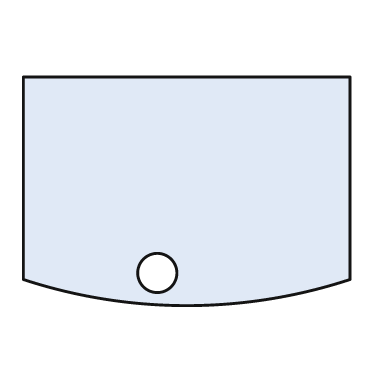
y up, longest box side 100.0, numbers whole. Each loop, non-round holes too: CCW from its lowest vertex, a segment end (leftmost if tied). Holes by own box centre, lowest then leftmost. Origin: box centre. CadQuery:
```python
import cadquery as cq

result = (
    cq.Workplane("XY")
    .moveTo(-50.0, -27.0)
    .threePointArc((0.0, -35.0), (50.0, -27.0))
    .lineTo(50.0, 35.0)
    .lineTo(-50.0, 35.0)
    .close()
    .moveTo(-9.0, -25.0)
    .circle(6.0)
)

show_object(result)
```